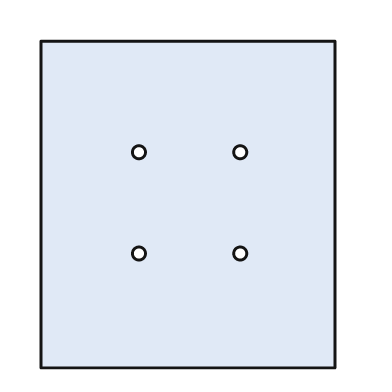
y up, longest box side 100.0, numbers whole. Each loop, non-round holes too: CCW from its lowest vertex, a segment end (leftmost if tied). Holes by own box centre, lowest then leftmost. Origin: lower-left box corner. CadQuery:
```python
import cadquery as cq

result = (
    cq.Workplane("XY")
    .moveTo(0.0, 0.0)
    .lineTo(90.0, 0.0)
    .lineTo(90.0, 100.0)
    .lineTo(0.0, 100.0)
    .close()
    .moveTo(30.0, 35.0)
    .circle(2.0)
    .moveTo(61.0, 35.0)
    .circle(2.0)
    .moveTo(30.0, 66.0)
    .circle(2.0)
    .moveTo(61.0, 66.0)
    .circle(2.0)
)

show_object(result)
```